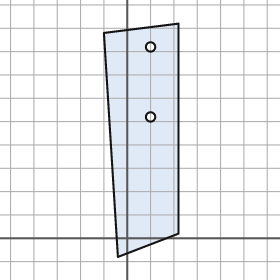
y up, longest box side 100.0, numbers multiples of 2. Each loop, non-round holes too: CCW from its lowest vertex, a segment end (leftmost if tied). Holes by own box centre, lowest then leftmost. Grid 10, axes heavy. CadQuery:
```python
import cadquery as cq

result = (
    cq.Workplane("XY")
    .moveTo(-4.0, -8.0)
    .lineTo(22.0, 2.0)
    .lineTo(22.0, 92.0)
    .lineTo(-10.0, 88.0)
    .close()
    .moveTo(10.0, 52.0)
    .circle(2.0)
    .moveTo(10.0, 82.0)
    .circle(2.0)
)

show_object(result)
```